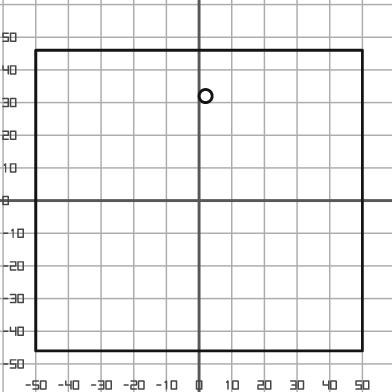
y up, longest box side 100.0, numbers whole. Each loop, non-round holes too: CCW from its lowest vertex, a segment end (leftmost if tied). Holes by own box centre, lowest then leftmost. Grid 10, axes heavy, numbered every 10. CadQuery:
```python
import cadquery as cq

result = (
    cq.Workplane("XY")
    .moveTo(-50.0, -46.0)
    .lineTo(50.0, -46.0)
    .lineTo(50.0, 46.0)
    .lineTo(-50.0, 46.0)
    .close()
    .moveTo(2.0, 32.0)
    .circle(2.0)
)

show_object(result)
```